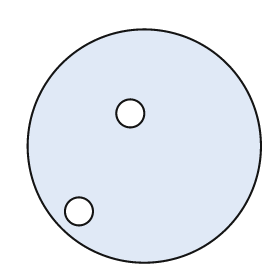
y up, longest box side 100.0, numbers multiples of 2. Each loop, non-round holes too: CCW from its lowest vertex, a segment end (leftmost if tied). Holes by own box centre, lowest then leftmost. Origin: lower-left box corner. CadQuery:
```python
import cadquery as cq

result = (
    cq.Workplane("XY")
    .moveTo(50.0, 50.0)
    .circle(50.0)
    .moveTo(22.0, 22.0)
    .circle(6.0)
    .moveTo(44.0, 64.0)
    .circle(6.0)
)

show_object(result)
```